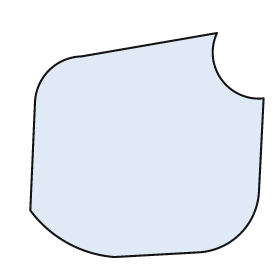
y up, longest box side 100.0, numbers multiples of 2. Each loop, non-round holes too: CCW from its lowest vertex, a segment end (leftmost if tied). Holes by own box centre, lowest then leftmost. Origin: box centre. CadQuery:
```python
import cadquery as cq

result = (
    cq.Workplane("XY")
    .moveTo(-14.0, -48.0)
    .lineTo(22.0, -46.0)
    .threePointArc((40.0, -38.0), (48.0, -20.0))
    .lineTo(50.0, 20.0)
    .threePointArc((32.0, 28.0), (30.0, 48.0))
    .lineTo(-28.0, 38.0)
    .threePointArc((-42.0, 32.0), (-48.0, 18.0))
    .lineTo(-50.0, -28.0)
    .threePointArc((-34.0, -42.0), (-14.0, -48.0))
    .close()
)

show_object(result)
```